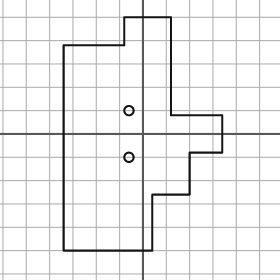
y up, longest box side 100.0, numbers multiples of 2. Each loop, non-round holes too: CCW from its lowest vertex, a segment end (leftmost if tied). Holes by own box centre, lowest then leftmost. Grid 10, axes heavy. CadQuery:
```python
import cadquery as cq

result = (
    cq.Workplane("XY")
    .moveTo(-34.0, -50.0)
    .lineTo(4.0, -50.0)
    .lineTo(4.0, -26.0)
    .lineTo(20.0, -26.0)
    .lineTo(20.0, -8.0)
    .lineTo(34.0, -8.0)
    .lineTo(34.0, 8.0)
    .lineTo(12.0, 8.0)
    .lineTo(12.0, 50.0)
    .lineTo(-8.0, 50.0)
    .lineTo(-8.0, 38.0)
    .lineTo(-34.0, 38.0)
    .close()
    .moveTo(-6.0, -10.0)
    .circle(2.0)
    .moveTo(-6.0, 10.0)
    .circle(2.0)
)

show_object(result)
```